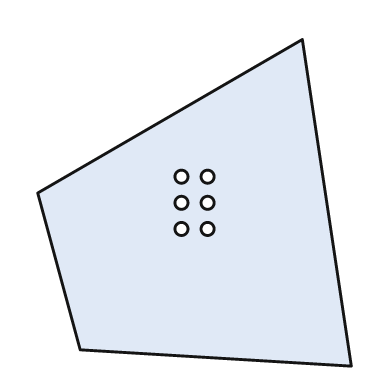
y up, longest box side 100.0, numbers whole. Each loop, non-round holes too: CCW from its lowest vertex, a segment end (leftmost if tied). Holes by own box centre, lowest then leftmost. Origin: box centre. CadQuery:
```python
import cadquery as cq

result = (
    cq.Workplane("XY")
    .moveTo(48.0, -50.0)
    .lineTo(33.0, 50.0)
    .lineTo(-48.0, 3.0)
    .lineTo(-35.0, -45.0)
    .close()
    .moveTo(-4.0, -8.0)
    .circle(2.0)
    .moveTo(4.0, -8.0)
    .circle(2.0)
    .moveTo(-4.0, 0.0)
    .circle(2.0)
    .moveTo(4.0, 0.0)
    .circle(2.0)
    .moveTo(-4.0, 8.0)
    .circle(2.0)
    .moveTo(4.0, 8.0)
    .circle(2.0)
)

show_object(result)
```